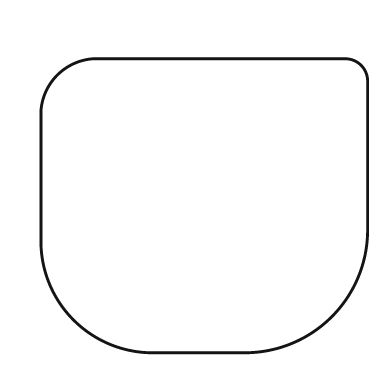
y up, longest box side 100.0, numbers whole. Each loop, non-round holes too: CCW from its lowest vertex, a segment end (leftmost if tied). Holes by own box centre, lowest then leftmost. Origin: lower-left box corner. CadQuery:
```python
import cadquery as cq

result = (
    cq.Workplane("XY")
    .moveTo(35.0, 0.0)
    .lineTo(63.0, 0.0)
    .threePointArc((89.0, 11.0), (100.0, 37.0))
    .lineTo(100.0, 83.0)
    .threePointArc((98.0, 88.0), (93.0, 90.0))
    .lineTo(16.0, 90.0)
    .threePointArc((5.0, 85.0), (0.0, 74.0))
    .lineTo(0.0, 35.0)
    .threePointArc((10.0, 10.0), (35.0, 0.0))
    .close()
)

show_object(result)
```